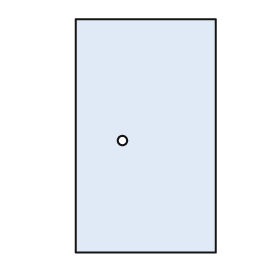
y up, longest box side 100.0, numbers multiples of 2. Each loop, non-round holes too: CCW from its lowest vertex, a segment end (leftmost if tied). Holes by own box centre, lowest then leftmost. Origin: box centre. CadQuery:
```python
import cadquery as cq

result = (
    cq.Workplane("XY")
    .moveTo(-30.0, -50.0)
    .lineTo(30.0, -50.0)
    .lineTo(30.0, 50.0)
    .lineTo(-30.0, 50.0)
    .close()
    .moveTo(-10.0, -2.0)
    .circle(2.0)
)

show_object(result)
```